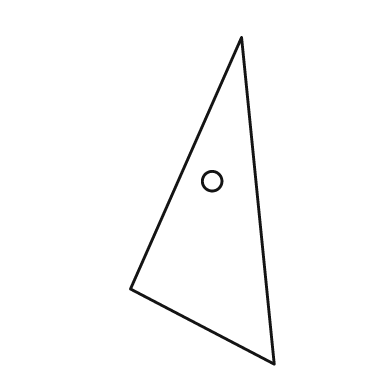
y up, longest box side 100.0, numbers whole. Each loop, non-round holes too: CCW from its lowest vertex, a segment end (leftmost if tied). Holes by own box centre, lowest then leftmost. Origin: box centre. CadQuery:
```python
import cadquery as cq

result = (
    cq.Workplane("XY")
    .moveTo(22.0, -50.0)
    .lineTo(12.0, 50.0)
    .lineTo(-22.0, -27.0)
    .close()
    .moveTo(3.0, 6.0)
    .circle(3.0)
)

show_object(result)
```